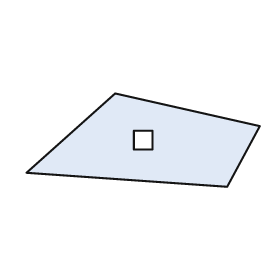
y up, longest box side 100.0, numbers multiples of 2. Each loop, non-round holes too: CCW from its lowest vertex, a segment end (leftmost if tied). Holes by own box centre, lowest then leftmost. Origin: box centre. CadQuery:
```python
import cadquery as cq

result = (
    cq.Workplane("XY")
    .moveTo(36.0, -20.0)
    .lineTo(50.0, 6.0)
    .lineTo(-12.0, 20.0)
    .lineTo(-50.0, -14.0)
    .close()
    .moveTo(-4.0, -4.0)
    .lineTo(4.0, -4.0)
    .lineTo(4.0, 4.0)
    .lineTo(-4.0, 4.0)
    .close()
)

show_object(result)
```